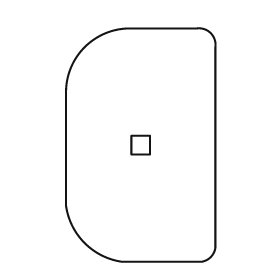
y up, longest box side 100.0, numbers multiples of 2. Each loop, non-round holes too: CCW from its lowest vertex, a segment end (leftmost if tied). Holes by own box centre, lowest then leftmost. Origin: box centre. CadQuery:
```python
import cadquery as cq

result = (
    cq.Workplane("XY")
    .moveTo(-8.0, -50.0)
    .lineTo(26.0, -50.0)
    .threePointArc((30.0, -48.0), (32.0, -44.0))
    .lineTo(32.0, 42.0)
    .threePointArc((30.0, 48.0), (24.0, 50.0))
    .lineTo(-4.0, 50.0)
    .threePointArc((-24.0, 42.0), (-32.0, 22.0))
    .lineTo(-32.0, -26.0)
    .threePointArc((-24.0, -42.0), (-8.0, -50.0))
    .close()
    .moveTo(-4.0, -4.0)
    .lineTo(4.0, -4.0)
    .lineTo(4.0, 4.0)
    .lineTo(-4.0, 4.0)
    .close()
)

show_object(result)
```